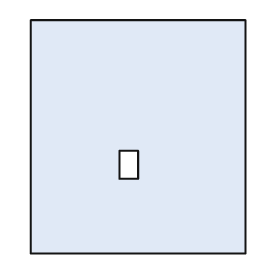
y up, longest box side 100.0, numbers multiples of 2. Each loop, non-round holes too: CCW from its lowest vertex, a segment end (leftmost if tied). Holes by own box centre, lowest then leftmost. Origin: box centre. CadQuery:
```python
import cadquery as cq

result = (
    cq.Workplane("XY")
    .moveTo(-46.0, -50.0)
    .lineTo(46.0, -50.0)
    .lineTo(46.0, 50.0)
    .lineTo(-46.0, 50.0)
    .close()
    .moveTo(-8.0, -18.0)
    .lineTo(0.0, -18.0)
    .lineTo(0.0, -6.0)
    .lineTo(-8.0, -6.0)
    .close()
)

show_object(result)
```